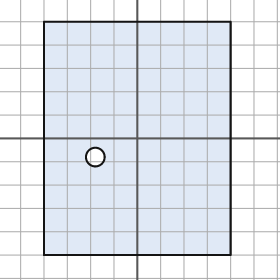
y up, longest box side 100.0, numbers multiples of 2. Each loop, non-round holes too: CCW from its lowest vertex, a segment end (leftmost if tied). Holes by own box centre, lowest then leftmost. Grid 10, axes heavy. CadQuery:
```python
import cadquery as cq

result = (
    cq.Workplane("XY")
    .moveTo(-40.0, -50.0)
    .lineTo(40.0, -50.0)
    .lineTo(40.0, 50.0)
    .lineTo(-40.0, 50.0)
    .close()
    .moveTo(-18.0, -8.0)
    .circle(4.0)
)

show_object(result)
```